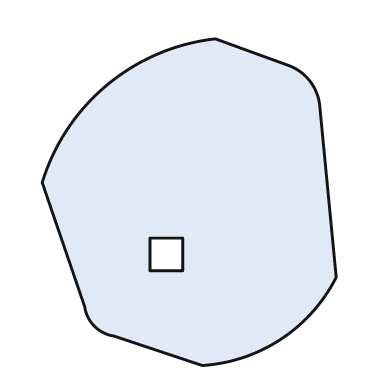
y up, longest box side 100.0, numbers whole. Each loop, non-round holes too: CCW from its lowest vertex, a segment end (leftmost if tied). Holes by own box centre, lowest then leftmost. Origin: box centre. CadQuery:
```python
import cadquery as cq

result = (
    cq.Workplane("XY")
    .moveTo(4.0, -50.0)
    .threePointArc((28.0, -42.0), (45.0, -23.0))
    .lineTo(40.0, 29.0)
    .threePointArc((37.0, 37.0), (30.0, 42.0))
    .lineTo(8.0, 50.0)
    .threePointArc((-25.0, 36.0), (-45.0, 6.0))
    .lineTo(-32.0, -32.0)
    .threePointArc((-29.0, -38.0), (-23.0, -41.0))
    .close()
    .moveTo(-12.0, -21.0)
    .lineTo(-2.0, -21.0)
    .lineTo(-2.0, -11.0)
    .lineTo(-12.0, -11.0)
    .close()
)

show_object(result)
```